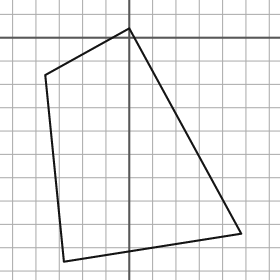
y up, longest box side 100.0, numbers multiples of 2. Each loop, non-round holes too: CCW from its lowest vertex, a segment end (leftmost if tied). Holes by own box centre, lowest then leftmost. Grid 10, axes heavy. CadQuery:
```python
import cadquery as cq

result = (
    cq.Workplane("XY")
    .moveTo(-28.0, -96.0)
    .lineTo(48.0, -84.0)
    .lineTo(0.0, 4.0)
    .lineTo(-36.0, -16.0)
    .close()
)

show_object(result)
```